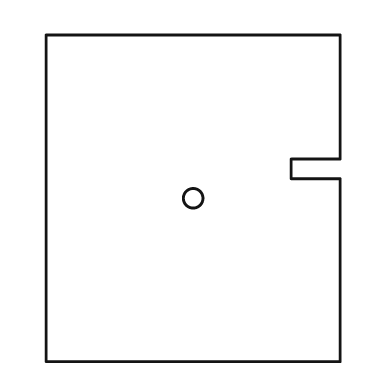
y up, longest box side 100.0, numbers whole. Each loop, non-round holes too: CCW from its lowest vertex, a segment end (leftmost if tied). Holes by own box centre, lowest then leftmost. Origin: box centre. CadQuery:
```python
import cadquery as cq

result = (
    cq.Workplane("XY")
    .moveTo(-45.0, -50.0)
    .lineTo(45.0, -50.0)
    .lineTo(45.0, 6.0)
    .lineTo(30.0, 6.0)
    .lineTo(30.0, 12.0)
    .lineTo(45.0, 12.0)
    .lineTo(45.0, 50.0)
    .lineTo(-45.0, 50.0)
    .close()
    .moveTo(0.0, 0.0)
    .circle(3.0)
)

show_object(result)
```